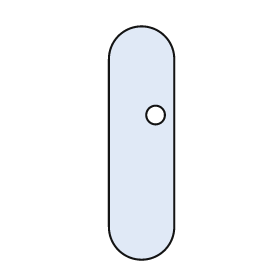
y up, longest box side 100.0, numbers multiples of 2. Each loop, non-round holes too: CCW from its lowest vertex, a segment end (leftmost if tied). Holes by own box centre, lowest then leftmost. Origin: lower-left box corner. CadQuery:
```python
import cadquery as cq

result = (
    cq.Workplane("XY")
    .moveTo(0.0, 14.0)
    .threePointArc((14.0, 0.0), (28.0, 14.0))
    .lineTo(28.0, 86.0)
    .threePointArc((14.0, 100.0), (0.0, 86.0))
    .close()
    .moveTo(20.0, 62.0)
    .circle(4.0)
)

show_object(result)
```